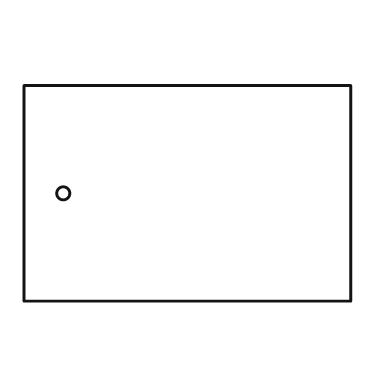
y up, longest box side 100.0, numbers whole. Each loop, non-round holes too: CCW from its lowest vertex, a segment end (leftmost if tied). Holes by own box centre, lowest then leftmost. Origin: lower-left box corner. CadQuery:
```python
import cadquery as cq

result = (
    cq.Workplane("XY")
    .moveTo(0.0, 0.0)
    .lineTo(100.0, 0.0)
    .lineTo(100.0, 66.0)
    .lineTo(0.0, 66.0)
    .close()
    .moveTo(12.0, 33.0)
    .circle(2.0)
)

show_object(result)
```